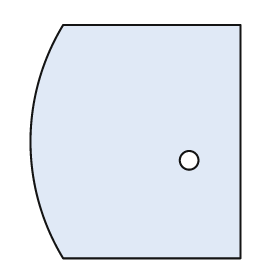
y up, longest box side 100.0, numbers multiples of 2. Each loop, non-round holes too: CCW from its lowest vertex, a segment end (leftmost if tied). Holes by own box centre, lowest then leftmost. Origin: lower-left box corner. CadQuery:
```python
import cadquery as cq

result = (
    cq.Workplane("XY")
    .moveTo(14.0, 0.0)
    .lineTo(90.0, 0.0)
    .lineTo(90.0, 100.0)
    .lineTo(14.0, 100.0)
    .threePointArc((0.0, 50.0), (14.0, 0.0))
    .close()
    .moveTo(68.0, 42.0)
    .circle(4.0)
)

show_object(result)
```